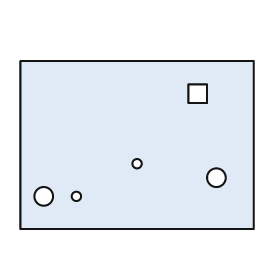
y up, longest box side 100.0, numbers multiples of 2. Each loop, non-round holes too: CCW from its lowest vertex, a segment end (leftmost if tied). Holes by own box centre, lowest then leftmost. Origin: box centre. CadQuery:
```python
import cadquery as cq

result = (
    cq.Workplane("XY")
    .moveTo(-50.0, -36.0)
    .lineTo(50.0, -36.0)
    .lineTo(50.0, 36.0)
    .lineTo(-50.0, 36.0)
    .close()
    .moveTo(-40.0, -22.0)
    .circle(4.0)
    .moveTo(-26.0, -22.0)
    .circle(2.0)
    .moveTo(34.0, -14.0)
    .circle(4.0)
    .moveTo(0.0, -8.0)
    .circle(2.0)
    .moveTo(22.0, 18.0)
    .lineTo(30.0, 18.0)
    .lineTo(30.0, 26.0)
    .lineTo(22.0, 26.0)
    .close()
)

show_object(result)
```